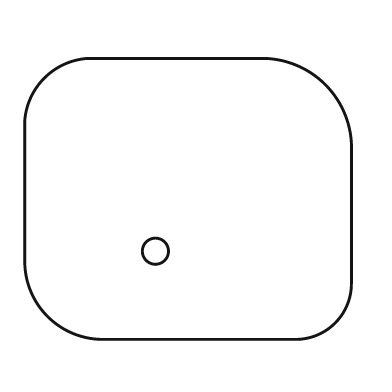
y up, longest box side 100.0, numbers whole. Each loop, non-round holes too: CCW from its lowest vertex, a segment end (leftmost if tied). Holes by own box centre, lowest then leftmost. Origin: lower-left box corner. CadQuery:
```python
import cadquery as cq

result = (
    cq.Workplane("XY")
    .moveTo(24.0, 0.0)
    .lineTo(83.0, 0.0)
    .threePointArc((95.0, 5.0), (100.0, 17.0))
    .lineTo(100.0, 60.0)
    .threePointArc((92.0, 78.0), (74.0, 86.0))
    .lineTo(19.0, 86.0)
    .threePointArc((6.0, 80.0), (0.0, 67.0))
    .lineTo(0.0, 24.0)
    .threePointArc((7.0, 7.0), (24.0, 0.0))
    .close()
    .moveTo(40.0, 27.0)
    .circle(4.0)
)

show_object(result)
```